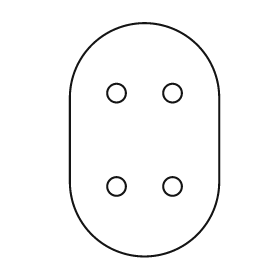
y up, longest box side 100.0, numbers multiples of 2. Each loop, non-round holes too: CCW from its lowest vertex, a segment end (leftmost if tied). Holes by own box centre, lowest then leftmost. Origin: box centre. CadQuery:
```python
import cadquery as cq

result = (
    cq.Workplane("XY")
    .moveTo(-32.0, -18.0)
    .threePointArc((0.0, -50.0), (32.0, -18.0))
    .lineTo(32.0, 18.0)
    .threePointArc((0.0, 50.0), (-32.0, 18.0))
    .close()
    .moveTo(-12.0, -20.0)
    .circle(4.0)
    .moveTo(12.0, -20.0)
    .circle(4.0)
    .moveTo(-12.0, 20.0)
    .circle(4.0)
    .moveTo(12.0, 20.0)
    .circle(4.0)
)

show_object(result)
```